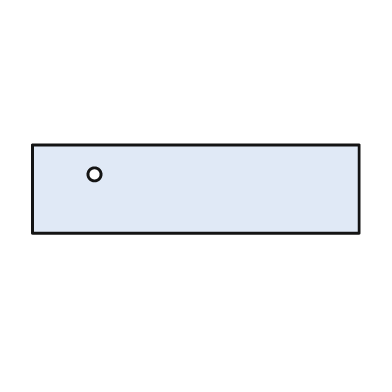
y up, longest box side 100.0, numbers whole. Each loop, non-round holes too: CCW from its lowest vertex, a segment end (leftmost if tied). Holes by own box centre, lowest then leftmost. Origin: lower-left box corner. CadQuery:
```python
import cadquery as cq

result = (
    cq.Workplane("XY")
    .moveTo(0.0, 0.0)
    .lineTo(100.0, 0.0)
    .lineTo(100.0, 27.0)
    .lineTo(0.0, 27.0)
    .close()
    .moveTo(19.0, 18.0)
    .circle(2.0)
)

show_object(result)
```